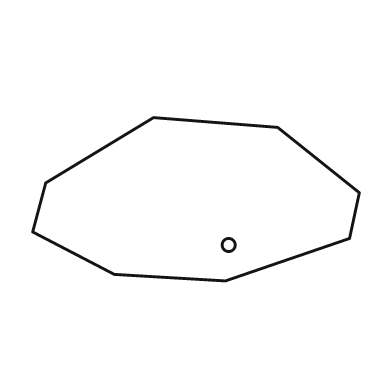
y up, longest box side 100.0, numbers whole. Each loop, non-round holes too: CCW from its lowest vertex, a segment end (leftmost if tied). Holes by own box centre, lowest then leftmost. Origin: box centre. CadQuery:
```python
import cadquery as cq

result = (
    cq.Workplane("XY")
    .moveTo(9.0, -25.0)
    .lineTo(47.0, -12.0)
    .lineTo(50.0, 2.0)
    .lineTo(25.0, 22.0)
    .lineTo(-13.0, 25.0)
    .lineTo(-46.0, 5.0)
    .lineTo(-50.0, -10.0)
    .lineTo(-25.0, -23.0)
    .close()
    .moveTo(10.0, -14.0)
    .circle(2.0)
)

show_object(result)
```